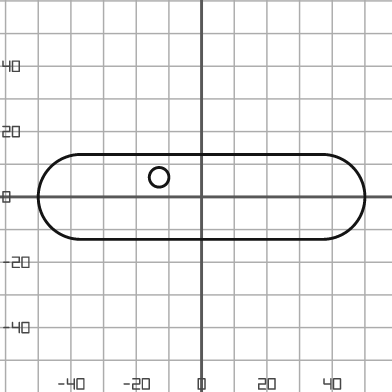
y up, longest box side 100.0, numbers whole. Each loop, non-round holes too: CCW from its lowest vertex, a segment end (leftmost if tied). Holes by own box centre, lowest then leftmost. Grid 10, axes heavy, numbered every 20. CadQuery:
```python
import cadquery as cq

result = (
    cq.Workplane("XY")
    .moveTo(-37.0, -13.0)
    .lineTo(37.0, -13.0)
    .threePointArc((50.0, 0.0), (37.0, 13.0))
    .lineTo(-37.0, 13.0)
    .threePointArc((-50.0, 0.0), (-37.0, -13.0))
    .close()
    .moveTo(-13.0, 6.0)
    .circle(3.0)
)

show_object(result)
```